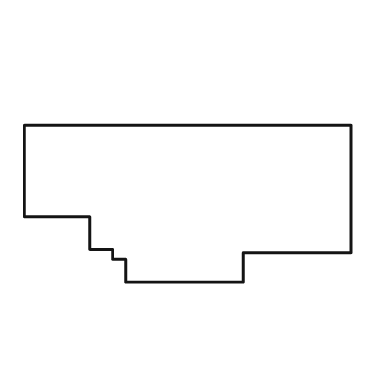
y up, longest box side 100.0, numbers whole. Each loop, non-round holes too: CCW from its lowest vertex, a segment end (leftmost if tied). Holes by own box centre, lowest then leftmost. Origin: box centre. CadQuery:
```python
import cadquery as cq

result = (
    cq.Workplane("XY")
    .moveTo(-19.0, -24.0)
    .lineTo(17.0, -24.0)
    .lineTo(17.0, -15.0)
    .lineTo(50.0, -15.0)
    .lineTo(50.0, 24.0)
    .lineTo(-50.0, 24.0)
    .lineTo(-50.0, -4.0)
    .lineTo(-30.0, -4.0)
    .lineTo(-30.0, -14.0)
    .lineTo(-23.0, -14.0)
    .lineTo(-23.0, -17.0)
    .lineTo(-19.0, -17.0)
    .close()
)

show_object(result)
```